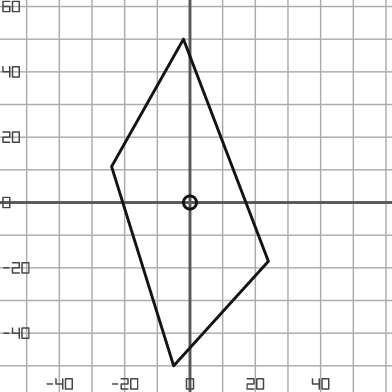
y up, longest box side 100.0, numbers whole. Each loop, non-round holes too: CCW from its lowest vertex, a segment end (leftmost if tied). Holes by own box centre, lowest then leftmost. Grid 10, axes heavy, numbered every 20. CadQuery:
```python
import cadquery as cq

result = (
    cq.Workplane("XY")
    .moveTo(-5.0, -50.0)
    .lineTo(24.0, -18.0)
    .lineTo(-2.0, 50.0)
    .lineTo(-24.0, 11.0)
    .close()
    .moveTo(0.0, 0.0)
    .circle(2.0)
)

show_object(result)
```